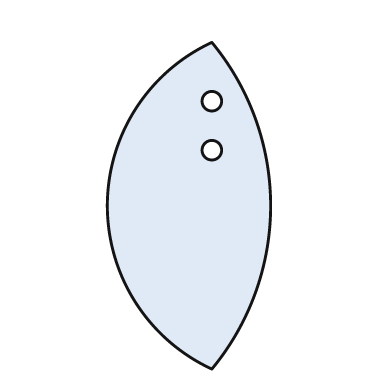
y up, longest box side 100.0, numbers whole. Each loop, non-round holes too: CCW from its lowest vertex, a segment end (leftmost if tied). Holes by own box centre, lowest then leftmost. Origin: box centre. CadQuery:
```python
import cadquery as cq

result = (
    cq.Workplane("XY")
    .moveTo(7.0, -50.0)
    .threePointArc((25.0, 0.0), (7.0, 50.0))
    .threePointArc((-25.0, 0.0), (7.0, -50.0))
    .close()
    .moveTo(7.0, 17.0)
    .circle(3.0)
    .moveTo(7.0, 32.0)
    .circle(3.0)
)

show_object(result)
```